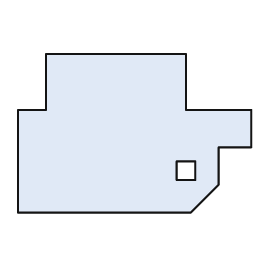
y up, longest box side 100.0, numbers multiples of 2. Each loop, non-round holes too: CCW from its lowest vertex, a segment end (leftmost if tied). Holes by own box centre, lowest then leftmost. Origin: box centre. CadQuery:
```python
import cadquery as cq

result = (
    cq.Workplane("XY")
    .moveTo(-50.0, -34.0)
    .lineTo(24.0, -34.0)
    .lineTo(36.0, -22.0)
    .lineTo(36.0, -6.0)
    .lineTo(50.0, -6.0)
    .lineTo(50.0, 10.0)
    .lineTo(22.0, 10.0)
    .lineTo(22.0, 34.0)
    .lineTo(-38.0, 34.0)
    .lineTo(-38.0, 10.0)
    .lineTo(-50.0, 10.0)
    .close()
    .moveTo(18.0, -20.0)
    .lineTo(26.0, -20.0)
    .lineTo(26.0, -12.0)
    .lineTo(18.0, -12.0)
    .close()
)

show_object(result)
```